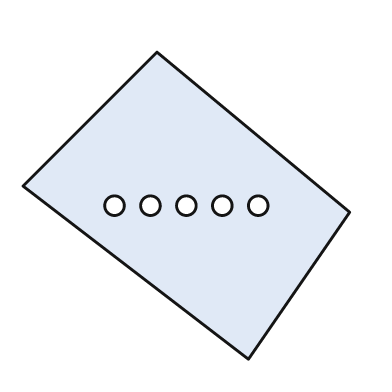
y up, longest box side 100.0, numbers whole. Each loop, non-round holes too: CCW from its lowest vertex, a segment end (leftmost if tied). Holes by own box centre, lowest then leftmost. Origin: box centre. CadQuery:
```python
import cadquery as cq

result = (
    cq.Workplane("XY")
    .moveTo(19.0, -47.0)
    .lineTo(50.0, -2.0)
    .lineTo(-9.0, 47.0)
    .lineTo(-50.0, 6.0)
    .close()
    .moveTo(-22.0, 0.0)
    .circle(3.0)
    .moveTo(-11.0, 0.0)
    .circle(3.0)
    .moveTo(0.0, 0.0)
    .circle(3.0)
    .moveTo(11.0, 0.0)
    .circle(3.0)
    .moveTo(22.0, 0.0)
    .circle(3.0)
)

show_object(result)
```